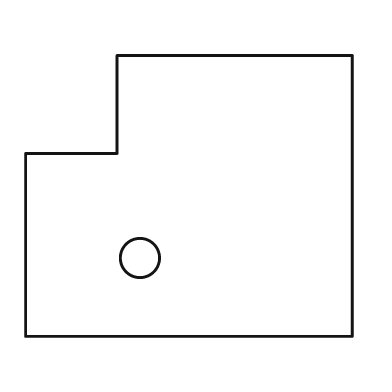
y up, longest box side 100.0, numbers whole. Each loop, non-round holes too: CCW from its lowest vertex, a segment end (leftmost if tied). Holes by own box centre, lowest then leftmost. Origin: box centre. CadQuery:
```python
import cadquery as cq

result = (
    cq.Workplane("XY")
    .moveTo(-50.0, -43.0)
    .lineTo(50.0, -43.0)
    .lineTo(50.0, 43.0)
    .lineTo(-22.0, 43.0)
    .lineTo(-22.0, 13.0)
    .lineTo(-50.0, 13.0)
    .close()
    .moveTo(-15.0, -19.0)
    .circle(6.0)
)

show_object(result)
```